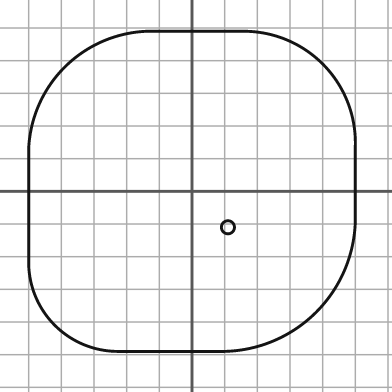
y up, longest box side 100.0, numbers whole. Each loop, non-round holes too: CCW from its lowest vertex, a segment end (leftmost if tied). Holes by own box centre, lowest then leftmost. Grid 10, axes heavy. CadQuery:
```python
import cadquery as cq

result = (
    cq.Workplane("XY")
    .moveTo(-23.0, -49.0)
    .lineTo(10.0, -49.0)
    .threePointArc((38.0, -37.0), (50.0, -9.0))
    .lineTo(50.0, 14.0)
    .threePointArc((40.0, 39.0), (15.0, 49.0))
    .lineTo(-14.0, 49.0)
    .threePointArc((-39.0, 38.0), (-50.0, 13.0))
    .lineTo(-50.0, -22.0)
    .threePointArc((-42.0, -41.0), (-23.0, -49.0))
    .close()
    .moveTo(11.0, -11.0)
    .circle(2.0)
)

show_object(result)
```